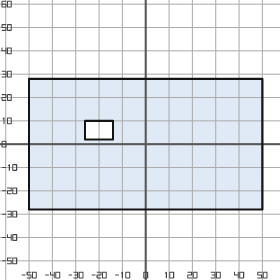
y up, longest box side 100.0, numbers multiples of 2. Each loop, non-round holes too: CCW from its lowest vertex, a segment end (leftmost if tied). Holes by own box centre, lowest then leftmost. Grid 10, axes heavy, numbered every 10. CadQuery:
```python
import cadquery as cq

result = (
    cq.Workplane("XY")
    .moveTo(-50.0, -28.0)
    .lineTo(50.0, -28.0)
    .lineTo(50.0, 28.0)
    .lineTo(-50.0, 28.0)
    .close()
    .moveTo(-26.0, 2.0)
    .lineTo(-14.0, 2.0)
    .lineTo(-14.0, 10.0)
    .lineTo(-26.0, 10.0)
    .close()
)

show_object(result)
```